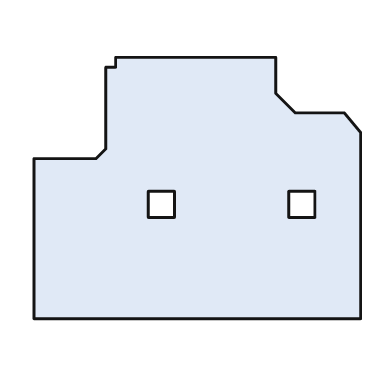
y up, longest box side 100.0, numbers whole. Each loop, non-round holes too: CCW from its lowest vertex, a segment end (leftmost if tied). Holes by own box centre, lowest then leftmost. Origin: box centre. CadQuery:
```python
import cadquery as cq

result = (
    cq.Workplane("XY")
    .moveTo(-50.0, -40.0)
    .lineTo(50.0, -40.0)
    .lineTo(50.0, 17.0)
    .lineTo(45.0, 23.0)
    .lineTo(30.0, 23.0)
    .lineTo(24.0, 29.0)
    .lineTo(24.0, 40.0)
    .lineTo(-25.0, 40.0)
    .lineTo(-25.0, 37.0)
    .lineTo(-28.0, 37.0)
    .lineTo(-28.0, 12.0)
    .lineTo(-31.0, 9.0)
    .lineTo(-50.0, 9.0)
    .close()
    .moveTo(-15.0, -9.0)
    .lineTo(-7.0, -9.0)
    .lineTo(-7.0, -1.0)
    .lineTo(-15.0, -1.0)
    .close()
    .moveTo(28.0, -9.0)
    .lineTo(36.0, -9.0)
    .lineTo(36.0, -1.0)
    .lineTo(28.0, -1.0)
    .close()
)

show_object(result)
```